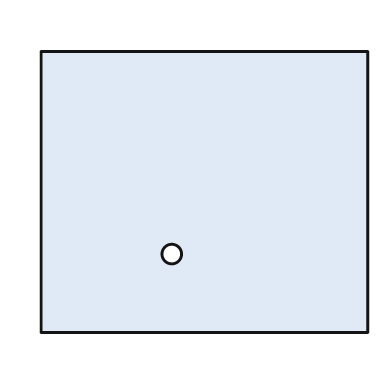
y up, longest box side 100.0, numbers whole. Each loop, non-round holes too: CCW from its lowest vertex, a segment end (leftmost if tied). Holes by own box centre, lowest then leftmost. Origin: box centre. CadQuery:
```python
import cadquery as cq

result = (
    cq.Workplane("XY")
    .moveTo(-50.0, -43.0)
    .lineTo(50.0, -43.0)
    .lineTo(50.0, 43.0)
    .lineTo(-50.0, 43.0)
    .close()
    .moveTo(-10.0, -19.0)
    .circle(3.0)
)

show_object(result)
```